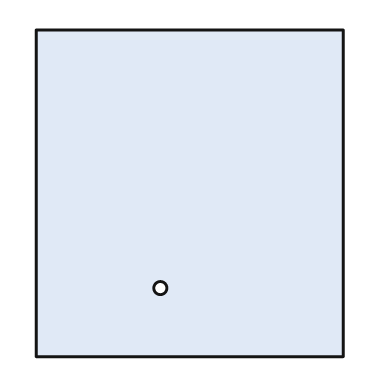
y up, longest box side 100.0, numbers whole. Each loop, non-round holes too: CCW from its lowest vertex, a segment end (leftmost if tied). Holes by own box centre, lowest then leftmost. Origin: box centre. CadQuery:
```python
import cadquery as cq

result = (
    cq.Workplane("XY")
    .moveTo(-47.0, -50.0)
    .lineTo(47.0, -50.0)
    .lineTo(47.0, 50.0)
    .lineTo(-47.0, 50.0)
    .close()
    .moveTo(-9.0, -29.0)
    .circle(2.0)
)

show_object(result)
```